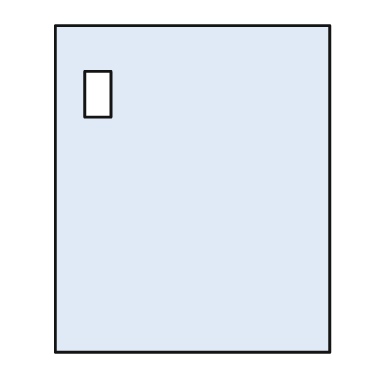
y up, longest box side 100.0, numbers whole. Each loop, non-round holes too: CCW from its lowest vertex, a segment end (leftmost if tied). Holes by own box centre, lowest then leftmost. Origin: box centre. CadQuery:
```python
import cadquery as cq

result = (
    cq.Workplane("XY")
    .moveTo(-42.0, -50.0)
    .lineTo(42.0, -50.0)
    .lineTo(42.0, 50.0)
    .lineTo(-42.0, 50.0)
    .close()
    .moveTo(-33.0, 22.0)
    .lineTo(-25.0, 22.0)
    .lineTo(-25.0, 36.0)
    .lineTo(-33.0, 36.0)
    .close()
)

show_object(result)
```